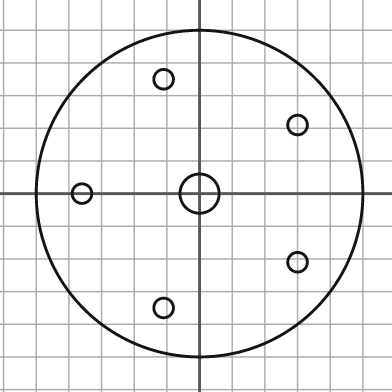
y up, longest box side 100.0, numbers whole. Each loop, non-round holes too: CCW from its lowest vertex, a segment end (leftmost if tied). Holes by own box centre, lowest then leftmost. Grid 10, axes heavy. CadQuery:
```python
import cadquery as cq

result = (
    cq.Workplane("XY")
    .moveTo(0.0, 0.0)
    .circle(50.0)
    .moveTo(-11.0, -35.0)
    .circle(3.0)
    .moveTo(30.0, -21.0)
    .circle(3.0)
    .moveTo(-36.0, 0.0)
    .circle(3.0)
    .moveTo(0.0, 0.0)
    .circle(6.0)
    .moveTo(30.0, 21.0)
    .circle(3.0)
    .moveTo(-11.0, 35.0)
    .circle(3.0)
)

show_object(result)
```